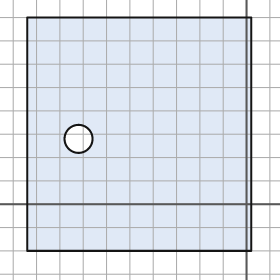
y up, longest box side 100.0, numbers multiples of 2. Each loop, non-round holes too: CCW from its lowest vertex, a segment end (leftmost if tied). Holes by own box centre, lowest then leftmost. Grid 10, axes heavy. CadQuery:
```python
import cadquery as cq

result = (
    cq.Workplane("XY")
    .moveTo(-94.0, -20.0)
    .lineTo(2.0, -20.0)
    .lineTo(2.0, 80.0)
    .lineTo(-94.0, 80.0)
    .close()
    .moveTo(-72.0, 28.0)
    .circle(6.0)
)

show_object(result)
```